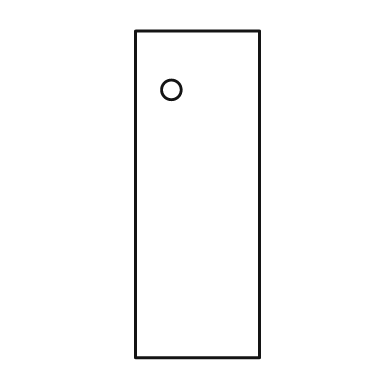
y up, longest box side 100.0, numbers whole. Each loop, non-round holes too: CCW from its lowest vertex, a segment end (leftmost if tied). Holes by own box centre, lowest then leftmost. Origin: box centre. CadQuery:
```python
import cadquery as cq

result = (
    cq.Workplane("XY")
    .moveTo(-19.0, -50.0)
    .lineTo(19.0, -50.0)
    .lineTo(19.0, 50.0)
    .lineTo(-19.0, 50.0)
    .close()
    .moveTo(-8.0, 32.0)
    .circle(3.0)
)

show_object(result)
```